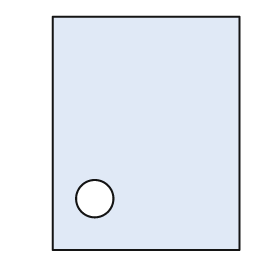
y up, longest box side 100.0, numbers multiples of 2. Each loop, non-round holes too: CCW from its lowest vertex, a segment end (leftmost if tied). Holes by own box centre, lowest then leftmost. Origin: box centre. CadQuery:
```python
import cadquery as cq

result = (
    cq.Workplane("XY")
    .moveTo(-40.0, -50.0)
    .lineTo(40.0, -50.0)
    .lineTo(40.0, 50.0)
    .lineTo(-40.0, 50.0)
    .close()
    .moveTo(-22.0, -28.0)
    .circle(8.0)
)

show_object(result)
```